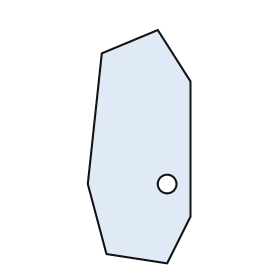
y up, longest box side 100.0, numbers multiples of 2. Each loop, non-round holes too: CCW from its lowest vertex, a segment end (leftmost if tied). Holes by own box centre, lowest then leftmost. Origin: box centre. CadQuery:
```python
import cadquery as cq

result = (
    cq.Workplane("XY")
    .moveTo(12.0, -50.0)
    .lineTo(22.0, -30.0)
    .lineTo(22.0, 28.0)
    .lineTo(8.0, 50.0)
    .lineTo(-16.0, 40.0)
    .lineTo(-22.0, -16.0)
    .lineTo(-14.0, -46.0)
    .close()
    .moveTo(12.0, -16.0)
    .circle(4.0)
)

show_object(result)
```